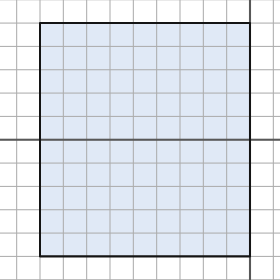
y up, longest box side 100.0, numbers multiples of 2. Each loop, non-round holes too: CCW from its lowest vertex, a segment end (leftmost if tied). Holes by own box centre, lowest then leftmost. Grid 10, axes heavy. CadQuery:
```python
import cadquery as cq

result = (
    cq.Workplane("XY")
    .moveTo(-90.0, -50.0)
    .lineTo(0.0, -50.0)
    .lineTo(0.0, 50.0)
    .lineTo(-90.0, 50.0)
    .close()
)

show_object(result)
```